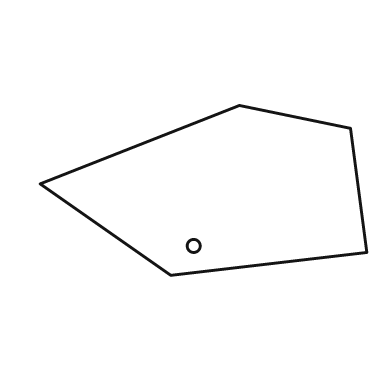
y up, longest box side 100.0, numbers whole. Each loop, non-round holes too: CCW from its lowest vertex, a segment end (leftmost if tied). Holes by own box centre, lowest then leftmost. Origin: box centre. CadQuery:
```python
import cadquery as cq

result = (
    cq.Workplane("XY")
    .moveTo(-10.0, -26.0)
    .lineTo(50.0, -19.0)
    .lineTo(45.0, 19.0)
    .lineTo(11.0, 26.0)
    .lineTo(-50.0, 2.0)
    .close()
    .moveTo(-3.0, -17.0)
    .circle(2.0)
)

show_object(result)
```